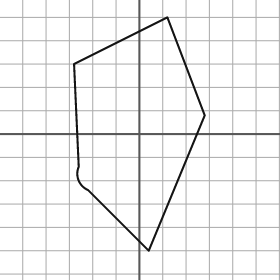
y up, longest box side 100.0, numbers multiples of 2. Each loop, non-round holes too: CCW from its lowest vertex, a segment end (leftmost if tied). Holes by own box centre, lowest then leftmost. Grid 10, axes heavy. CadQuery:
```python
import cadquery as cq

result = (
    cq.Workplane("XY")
    .moveTo(4.0, -50.0)
    .lineTo(28.0, 8.0)
    .lineTo(12.0, 50.0)
    .lineTo(-28.0, 30.0)
    .lineTo(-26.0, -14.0)
    .threePointArc((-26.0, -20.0), (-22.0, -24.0))
    .close()
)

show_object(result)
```